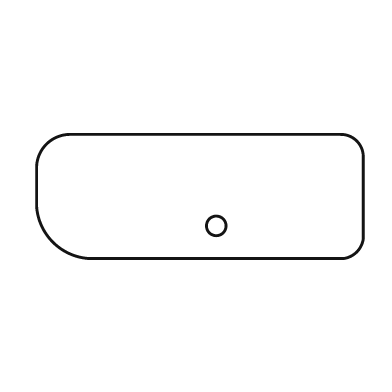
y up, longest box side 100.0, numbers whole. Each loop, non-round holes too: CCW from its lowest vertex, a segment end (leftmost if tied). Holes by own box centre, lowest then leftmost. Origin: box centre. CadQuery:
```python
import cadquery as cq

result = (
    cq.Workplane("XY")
    .moveTo(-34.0, -19.0)
    .lineTo(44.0, -19.0)
    .threePointArc((48.0, -17.0), (50.0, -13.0))
    .lineTo(50.0, 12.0)
    .threePointArc((48.0, 17.0), (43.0, 19.0))
    .lineTo(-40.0, 19.0)
    .threePointArc((-47.0, 16.0), (-50.0, 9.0))
    .lineTo(-50.0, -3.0)
    .threePointArc((-45.0, -14.0), (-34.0, -19.0))
    .close()
    .moveTo(5.0, -9.0)
    .circle(3.0)
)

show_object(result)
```